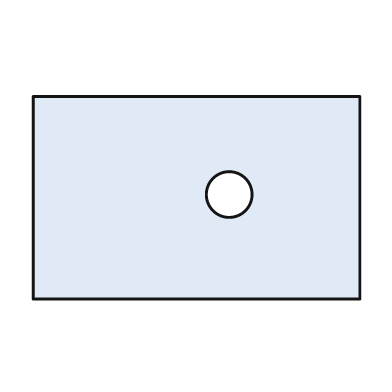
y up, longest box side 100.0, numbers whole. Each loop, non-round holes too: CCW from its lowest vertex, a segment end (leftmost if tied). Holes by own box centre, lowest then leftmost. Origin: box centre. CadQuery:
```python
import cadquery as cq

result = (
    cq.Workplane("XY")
    .moveTo(-50.0, -31.0)
    .lineTo(50.0, -31.0)
    .lineTo(50.0, 31.0)
    .lineTo(-50.0, 31.0)
    .close()
    .moveTo(10.0, 1.0)
    .circle(7.0)
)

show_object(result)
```